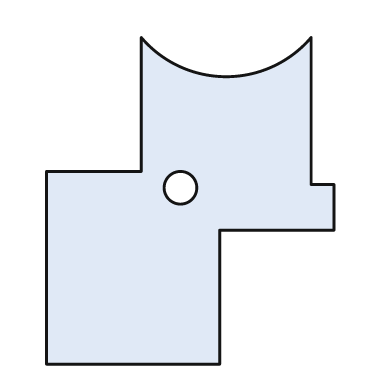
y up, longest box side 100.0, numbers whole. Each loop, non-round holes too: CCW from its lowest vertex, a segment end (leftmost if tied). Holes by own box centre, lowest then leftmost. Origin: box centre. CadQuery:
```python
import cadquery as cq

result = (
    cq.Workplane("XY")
    .moveTo(-44.0, -50.0)
    .lineTo(9.0, -50.0)
    .lineTo(9.0, -9.0)
    .lineTo(44.0, -9.0)
    .lineTo(44.0, 5.0)
    .lineTo(37.0, 5.0)
    .lineTo(37.0, 50.0)
    .threePointArc((11.0, 38.0), (-15.0, 50.0))
    .lineTo(-15.0, 9.0)
    .lineTo(-44.0, 9.0)
    .close()
    .moveTo(-3.0, 4.0)
    .circle(5.0)
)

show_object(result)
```